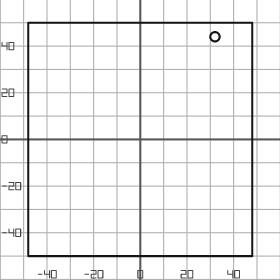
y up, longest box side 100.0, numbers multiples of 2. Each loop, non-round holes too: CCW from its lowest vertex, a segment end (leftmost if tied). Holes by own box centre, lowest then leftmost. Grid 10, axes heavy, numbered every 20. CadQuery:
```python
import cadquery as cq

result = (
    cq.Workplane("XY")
    .moveTo(-48.0, -50.0)
    .lineTo(48.0, -50.0)
    .lineTo(48.0, 50.0)
    .lineTo(-48.0, 50.0)
    .close()
    .moveTo(32.0, 44.0)
    .circle(2.0)
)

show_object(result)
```